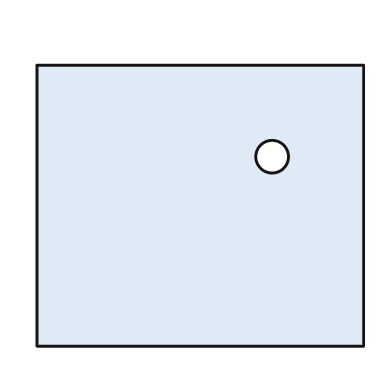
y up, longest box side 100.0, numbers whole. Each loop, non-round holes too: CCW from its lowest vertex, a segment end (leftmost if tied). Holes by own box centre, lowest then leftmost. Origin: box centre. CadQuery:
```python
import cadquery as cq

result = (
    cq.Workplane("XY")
    .moveTo(-50.0, -43.0)
    .lineTo(50.0, -43.0)
    .lineTo(50.0, 43.0)
    .lineTo(-50.0, 43.0)
    .close()
    .moveTo(22.0, 15.0)
    .circle(5.0)
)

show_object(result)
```